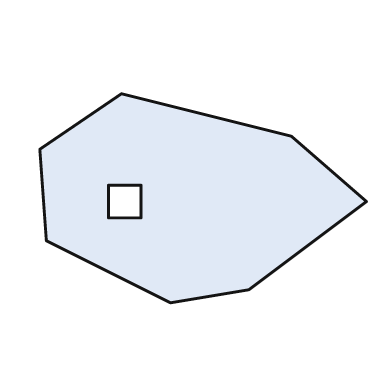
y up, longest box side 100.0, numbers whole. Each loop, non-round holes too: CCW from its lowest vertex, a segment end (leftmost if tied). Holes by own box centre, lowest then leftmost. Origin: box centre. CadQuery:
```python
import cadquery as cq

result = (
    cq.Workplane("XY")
    .moveTo(-10.0, -32.0)
    .lineTo(14.0, -28.0)
    .lineTo(50.0, -1.0)
    .lineTo(27.0, 19.0)
    .lineTo(-25.0, 32.0)
    .lineTo(-50.0, 15.0)
    .lineTo(-48.0, -13.0)
    .close()
    .moveTo(-29.0, -6.0)
    .lineTo(-19.0, -6.0)
    .lineTo(-19.0, 4.0)
    .lineTo(-29.0, 4.0)
    .close()
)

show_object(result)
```